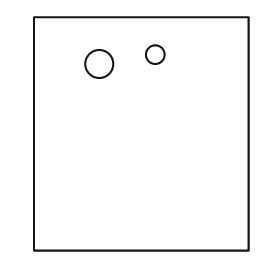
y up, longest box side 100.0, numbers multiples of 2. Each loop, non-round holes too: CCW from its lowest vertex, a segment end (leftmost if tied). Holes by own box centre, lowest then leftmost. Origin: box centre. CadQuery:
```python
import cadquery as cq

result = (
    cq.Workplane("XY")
    .moveTo(-46.0, -50.0)
    .lineTo(46.0, -50.0)
    .lineTo(46.0, 50.0)
    .lineTo(-46.0, 50.0)
    .close()
    .moveTo(-18.0, 30.0)
    .circle(6.0)
    .moveTo(6.0, 34.0)
    .circle(4.0)
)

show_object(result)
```